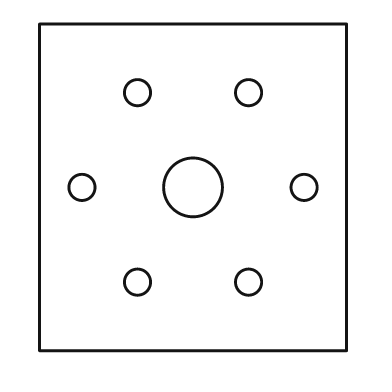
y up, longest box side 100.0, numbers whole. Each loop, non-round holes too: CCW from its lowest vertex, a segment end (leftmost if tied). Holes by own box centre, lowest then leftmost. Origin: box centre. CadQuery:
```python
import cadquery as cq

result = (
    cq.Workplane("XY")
    .moveTo(-47.0, -50.0)
    .lineTo(47.0, -50.0)
    .lineTo(47.0, 50.0)
    .lineTo(-47.0, 50.0)
    .close()
    .moveTo(-17.0, -29.0)
    .circle(4.0)
    .moveTo(17.0, -29.0)
    .circle(4.0)
    .moveTo(-34.0, 0.0)
    .circle(4.0)
    .moveTo(0.0, 0.0)
    .circle(9.0)
    .moveTo(34.0, 0.0)
    .circle(4.0)
    .moveTo(-17.0, 29.0)
    .circle(4.0)
    .moveTo(17.0, 29.0)
    .circle(4.0)
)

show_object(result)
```